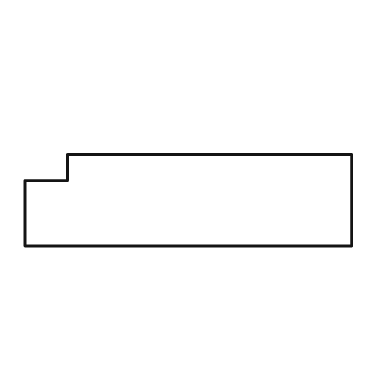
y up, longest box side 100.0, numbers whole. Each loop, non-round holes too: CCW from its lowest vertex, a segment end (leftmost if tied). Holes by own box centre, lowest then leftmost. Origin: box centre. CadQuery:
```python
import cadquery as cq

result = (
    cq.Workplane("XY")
    .moveTo(-50.0, -14.0)
    .lineTo(50.0, -14.0)
    .lineTo(50.0, 14.0)
    .lineTo(-37.0, 14.0)
    .lineTo(-37.0, 6.0)
    .lineTo(-50.0, 6.0)
    .close()
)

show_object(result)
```